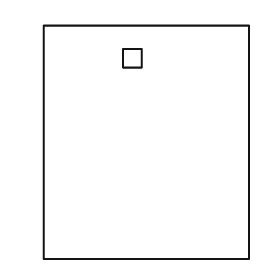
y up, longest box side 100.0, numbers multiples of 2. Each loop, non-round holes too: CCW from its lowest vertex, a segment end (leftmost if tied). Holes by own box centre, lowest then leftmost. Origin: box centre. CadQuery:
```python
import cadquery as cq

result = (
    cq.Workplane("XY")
    .moveTo(-44.0, -50.0)
    .lineTo(44.0, -50.0)
    .lineTo(44.0, 50.0)
    .lineTo(-44.0, 50.0)
    .close()
    .moveTo(-10.0, 32.0)
    .lineTo(-2.0, 32.0)
    .lineTo(-2.0, 40.0)
    .lineTo(-10.0, 40.0)
    .close()
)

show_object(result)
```